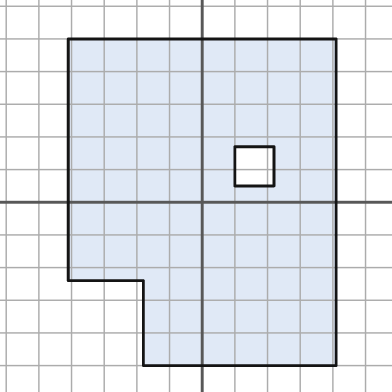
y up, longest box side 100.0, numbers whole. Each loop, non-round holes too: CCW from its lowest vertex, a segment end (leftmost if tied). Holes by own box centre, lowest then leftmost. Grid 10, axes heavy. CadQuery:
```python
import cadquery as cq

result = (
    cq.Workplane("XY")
    .moveTo(-18.0, -50.0)
    .lineTo(41.0, -50.0)
    .lineTo(41.0, 50.0)
    .lineTo(-41.0, 50.0)
    .lineTo(-41.0, -24.0)
    .lineTo(-18.0, -24.0)
    .close()
    .moveTo(10.0, 5.0)
    .lineTo(22.0, 5.0)
    .lineTo(22.0, 17.0)
    .lineTo(10.0, 17.0)
    .close()
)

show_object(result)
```